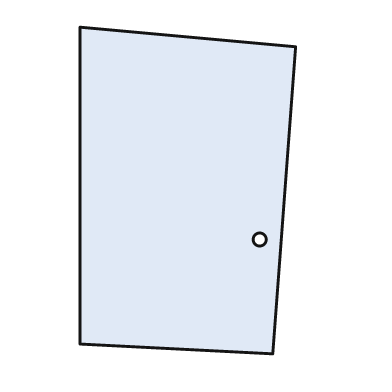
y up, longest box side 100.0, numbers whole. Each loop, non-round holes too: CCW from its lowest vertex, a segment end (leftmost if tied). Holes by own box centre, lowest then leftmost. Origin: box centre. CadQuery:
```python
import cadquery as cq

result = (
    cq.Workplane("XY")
    .moveTo(26.0, -50.0)
    .lineTo(33.0, 44.0)
    .lineTo(-33.0, 50.0)
    .lineTo(-33.0, -47.0)
    .close()
    .moveTo(22.0, -15.0)
    .circle(2.0)
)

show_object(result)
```